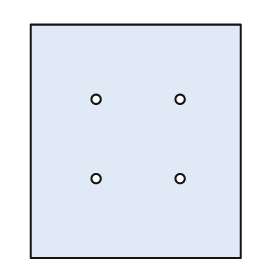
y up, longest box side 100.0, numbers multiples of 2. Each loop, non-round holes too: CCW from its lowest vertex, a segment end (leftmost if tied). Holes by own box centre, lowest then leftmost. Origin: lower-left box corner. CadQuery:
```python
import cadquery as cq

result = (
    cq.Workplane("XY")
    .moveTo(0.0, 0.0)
    .lineTo(90.0, 0.0)
    .lineTo(90.0, 100.0)
    .lineTo(0.0, 100.0)
    .close()
    .moveTo(28.0, 34.0)
    .circle(2.0)
    .moveTo(64.0, 34.0)
    .circle(2.0)
    .moveTo(28.0, 68.0)
    .circle(2.0)
    .moveTo(64.0, 68.0)
    .circle(2.0)
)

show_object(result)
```